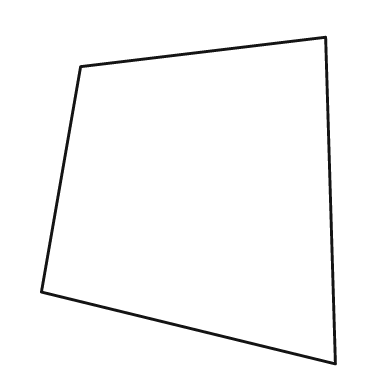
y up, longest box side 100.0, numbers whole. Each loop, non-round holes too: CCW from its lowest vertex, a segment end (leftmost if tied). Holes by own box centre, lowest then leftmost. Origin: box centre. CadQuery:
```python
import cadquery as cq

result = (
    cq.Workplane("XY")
    .moveTo(45.0, -50.0)
    .lineTo(42.0, 50.0)
    .lineTo(-33.0, 41.0)
    .lineTo(-45.0, -28.0)
    .close()
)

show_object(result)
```